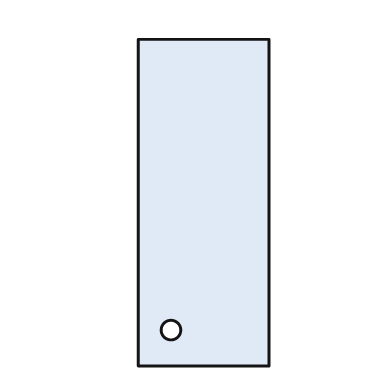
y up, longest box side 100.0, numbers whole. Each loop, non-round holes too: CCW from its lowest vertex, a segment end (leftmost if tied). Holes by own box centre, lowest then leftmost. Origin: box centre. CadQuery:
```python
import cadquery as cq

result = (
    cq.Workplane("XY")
    .moveTo(-20.0, -50.0)
    .lineTo(20.0, -50.0)
    .lineTo(20.0, 50.0)
    .lineTo(-20.0, 50.0)
    .close()
    .moveTo(-10.0, -39.0)
    .circle(3.0)
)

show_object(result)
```